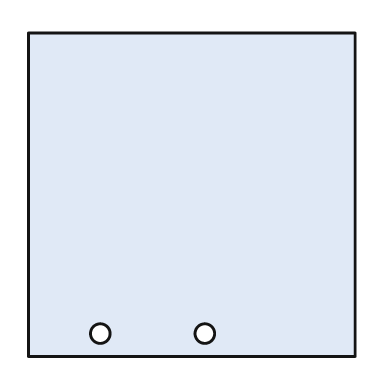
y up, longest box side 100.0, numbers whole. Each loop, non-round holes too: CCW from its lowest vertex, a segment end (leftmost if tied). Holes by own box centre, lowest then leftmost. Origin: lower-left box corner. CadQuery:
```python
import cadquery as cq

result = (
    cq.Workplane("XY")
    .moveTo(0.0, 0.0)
    .lineTo(100.0, 0.0)
    .lineTo(100.0, 99.0)
    .lineTo(0.0, 99.0)
    .close()
    .moveTo(22.0, 7.0)
    .circle(3.0)
    .moveTo(54.0, 7.0)
    .circle(3.0)
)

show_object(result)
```